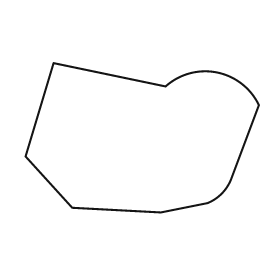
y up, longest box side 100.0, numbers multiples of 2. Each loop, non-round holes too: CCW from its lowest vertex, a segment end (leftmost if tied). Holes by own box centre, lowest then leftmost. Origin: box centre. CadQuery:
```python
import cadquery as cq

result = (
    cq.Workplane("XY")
    .moveTo(8.0, -32.0)
    .lineTo(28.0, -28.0)
    .threePointArc((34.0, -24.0), (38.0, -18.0))
    .lineTo(50.0, 14.0)
    .threePointArc((32.0, 28.0), (10.0, 22.0))
    .lineTo(-38.0, 32.0)
    .lineTo(-50.0, -8.0)
    .lineTo(-30.0, -30.0)
    .close()
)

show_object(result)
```